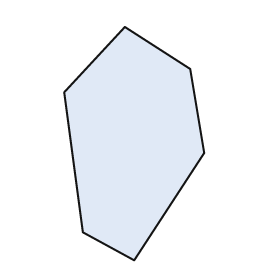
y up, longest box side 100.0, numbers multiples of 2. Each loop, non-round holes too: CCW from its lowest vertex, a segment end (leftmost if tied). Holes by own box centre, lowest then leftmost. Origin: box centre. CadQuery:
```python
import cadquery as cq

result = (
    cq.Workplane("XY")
    .moveTo(0.0, -50.0)
    .lineTo(30.0, -4.0)
    .lineTo(24.0, 32.0)
    .lineTo(-4.0, 50.0)
    .lineTo(-30.0, 22.0)
    .lineTo(-22.0, -38.0)
    .close()
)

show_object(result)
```